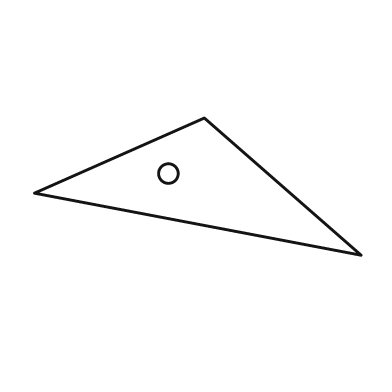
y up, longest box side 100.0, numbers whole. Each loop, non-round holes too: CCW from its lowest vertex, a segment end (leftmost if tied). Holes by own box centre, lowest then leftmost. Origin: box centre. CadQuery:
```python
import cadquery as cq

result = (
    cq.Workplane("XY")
    .moveTo(50.0, -21.0)
    .lineTo(2.0, 21.0)
    .lineTo(-50.0, -2.0)
    .close()
    .moveTo(-9.0, 4.0)
    .circle(3.0)
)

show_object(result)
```